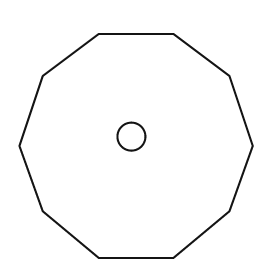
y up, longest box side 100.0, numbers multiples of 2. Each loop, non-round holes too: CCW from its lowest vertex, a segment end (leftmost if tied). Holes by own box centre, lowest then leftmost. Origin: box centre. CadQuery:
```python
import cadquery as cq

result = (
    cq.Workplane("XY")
    .moveTo(-16.0, -48.0)
    .lineTo(16.0, -48.0)
    .lineTo(40.0, -28.0)
    .lineTo(50.0, 0.0)
    .lineTo(40.0, 30.0)
    .lineTo(16.0, 48.0)
    .lineTo(-16.0, 48.0)
    .lineTo(-40.0, 30.0)
    .lineTo(-50.0, 0.0)
    .lineTo(-40.0, -28.0)
    .close()
    .moveTo(-2.0, 4.0)
    .circle(6.0)
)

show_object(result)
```